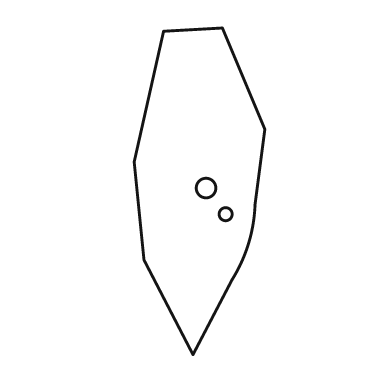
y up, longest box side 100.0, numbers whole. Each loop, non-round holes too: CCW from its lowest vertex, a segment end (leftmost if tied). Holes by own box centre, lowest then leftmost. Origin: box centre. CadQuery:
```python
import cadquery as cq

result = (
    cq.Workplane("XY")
    .moveTo(-2.0, -50.0)
    .lineTo(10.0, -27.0)
    .threePointArc((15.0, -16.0), (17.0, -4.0))
    .lineTo(20.0, 19.0)
    .lineTo(7.0, 50.0)
    .lineTo(-11.0, 49.0)
    .lineTo(-20.0, 9.0)
    .lineTo(-17.0, -21.0)
    .close()
    .moveTo(8.0, -7.0)
    .circle(2.0)
    .moveTo(2.0, 1.0)
    .circle(3.0)
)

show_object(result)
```